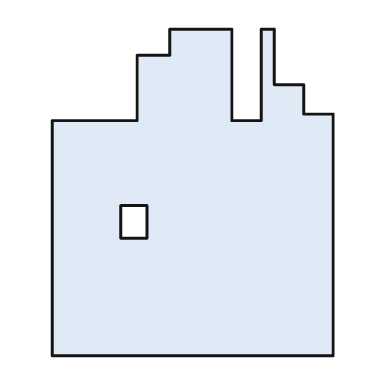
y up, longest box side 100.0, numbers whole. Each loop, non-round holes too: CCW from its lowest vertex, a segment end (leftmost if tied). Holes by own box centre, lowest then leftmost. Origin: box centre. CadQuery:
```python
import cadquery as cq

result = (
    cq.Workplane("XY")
    .moveTo(-43.0, -50.0)
    .lineTo(43.0, -50.0)
    .lineTo(43.0, 24.0)
    .lineTo(34.0, 24.0)
    .lineTo(34.0, 33.0)
    .lineTo(25.0, 33.0)
    .lineTo(25.0, 50.0)
    .lineTo(21.0, 50.0)
    .lineTo(21.0, 22.0)
    .lineTo(12.0, 22.0)
    .lineTo(12.0, 50.0)
    .lineTo(-7.0, 50.0)
    .lineTo(-7.0, 42.0)
    .lineTo(-17.0, 42.0)
    .lineTo(-17.0, 22.0)
    .lineTo(-43.0, 22.0)
    .close()
    .moveTo(-22.0, -14.0)
    .lineTo(-14.0, -14.0)
    .lineTo(-14.0, -4.0)
    .lineTo(-22.0, -4.0)
    .close()
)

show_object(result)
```